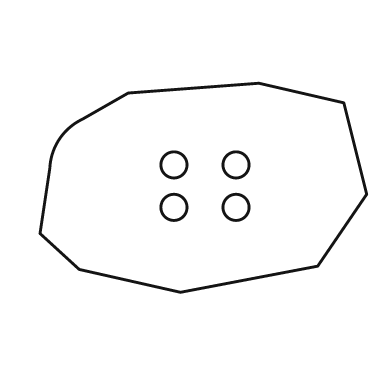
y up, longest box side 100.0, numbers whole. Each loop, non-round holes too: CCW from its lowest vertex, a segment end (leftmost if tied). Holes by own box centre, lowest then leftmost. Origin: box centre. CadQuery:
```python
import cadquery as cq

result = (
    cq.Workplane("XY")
    .moveTo(-7.0, -32.0)
    .lineTo(35.0, -24.0)
    .lineTo(50.0, -2.0)
    .lineTo(43.0, 26.0)
    .lineTo(17.0, 32.0)
    .lineTo(-23.0, 29.0)
    .lineTo(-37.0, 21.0)
    .threePointArc((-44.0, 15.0), (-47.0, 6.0))
    .lineTo(-50.0, -14.0)
    .lineTo(-38.0, -25.0)
    .close()
    .moveTo(-9.0, -6.0)
    .circle(4.0)
    .moveTo(10.0, -6.0)
    .circle(4.0)
    .moveTo(-9.0, 7.0)
    .circle(4.0)
    .moveTo(10.0, 7.0)
    .circle(4.0)
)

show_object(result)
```